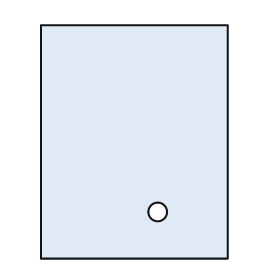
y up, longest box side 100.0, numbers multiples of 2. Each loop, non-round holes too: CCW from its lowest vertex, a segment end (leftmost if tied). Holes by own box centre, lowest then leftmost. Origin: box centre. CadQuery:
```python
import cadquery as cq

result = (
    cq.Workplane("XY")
    .moveTo(-40.0, -50.0)
    .lineTo(40.0, -50.0)
    .lineTo(40.0, 50.0)
    .lineTo(-40.0, 50.0)
    .close()
    .moveTo(10.0, -30.0)
    .circle(4.0)
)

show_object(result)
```